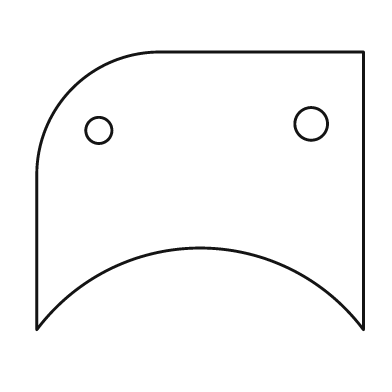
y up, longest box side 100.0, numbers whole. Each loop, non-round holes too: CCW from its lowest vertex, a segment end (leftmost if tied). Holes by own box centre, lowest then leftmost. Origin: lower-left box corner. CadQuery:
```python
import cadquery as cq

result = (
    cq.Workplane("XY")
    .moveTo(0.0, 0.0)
    .threePointArc((50.0, 25.0), (100.0, 0.0))
    .lineTo(100.0, 85.0)
    .lineTo(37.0, 85.0)
    .threePointArc((11.0, 74.0), (0.0, 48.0))
    .close()
    .moveTo(19.0, 61.0)
    .circle(4.0)
    .moveTo(84.0, 63.0)
    .circle(5.0)
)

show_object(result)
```